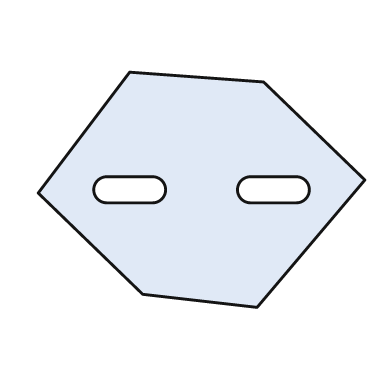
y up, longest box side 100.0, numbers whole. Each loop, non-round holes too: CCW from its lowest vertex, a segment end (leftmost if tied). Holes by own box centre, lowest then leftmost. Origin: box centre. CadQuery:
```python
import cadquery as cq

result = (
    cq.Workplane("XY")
    .moveTo(17.0, -36.0)
    .lineTo(50.0, 3.0)
    .lineTo(19.0, 33.0)
    .lineTo(-22.0, 36.0)
    .lineTo(-50.0, -1.0)
    .lineTo(-18.0, -32.0)
    .close()
    .moveTo(-29.0, -4.0)
    .lineTo(-15.0, -4.0)
    .threePointArc((-11.0, 0.0), (-15.0, 4.0))
    .lineTo(-29.0, 4.0)
    .threePointArc((-33.0, 0.0), (-29.0, -4.0))
    .close()
    .moveTo(15.0, -4.0)
    .lineTo(29.0, -4.0)
    .threePointArc((33.0, 0.0), (29.0, 4.0))
    .lineTo(15.0, 4.0)
    .threePointArc((11.0, 0.0), (15.0, -4.0))
    .close()
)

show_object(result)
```